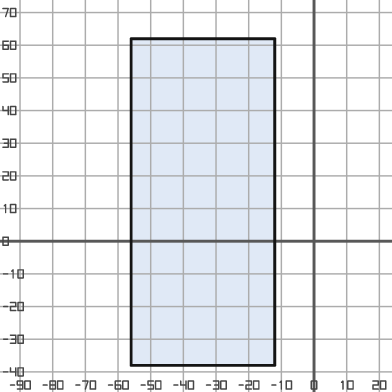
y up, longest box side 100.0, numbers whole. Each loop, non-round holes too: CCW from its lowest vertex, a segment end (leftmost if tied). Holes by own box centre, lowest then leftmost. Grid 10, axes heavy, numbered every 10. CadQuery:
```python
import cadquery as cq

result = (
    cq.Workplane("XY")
    .moveTo(-56.0, -38.0)
    .lineTo(-12.0, -38.0)
    .lineTo(-12.0, 62.0)
    .lineTo(-56.0, 62.0)
    .close()
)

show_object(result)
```